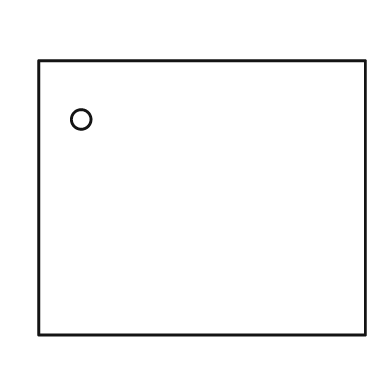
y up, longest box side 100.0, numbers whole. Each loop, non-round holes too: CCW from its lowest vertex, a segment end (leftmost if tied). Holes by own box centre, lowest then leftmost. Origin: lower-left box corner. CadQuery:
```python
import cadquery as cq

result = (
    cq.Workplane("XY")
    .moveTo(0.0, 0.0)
    .lineTo(100.0, 0.0)
    .lineTo(100.0, 84.0)
    .lineTo(0.0, 84.0)
    .close()
    .moveTo(13.0, 66.0)
    .circle(3.0)
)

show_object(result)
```